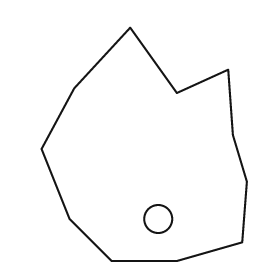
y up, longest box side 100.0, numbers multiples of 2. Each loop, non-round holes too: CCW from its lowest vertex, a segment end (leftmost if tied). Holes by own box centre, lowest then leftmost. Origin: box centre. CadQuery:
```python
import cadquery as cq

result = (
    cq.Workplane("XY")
    .moveTo(-14.0, -50.0)
    .lineTo(14.0, -50.0)
    .lineTo(42.0, -42.0)
    .lineTo(44.0, -16.0)
    .lineTo(38.0, 4.0)
    .lineTo(36.0, 32.0)
    .lineTo(14.0, 22.0)
    .lineTo(-6.0, 50.0)
    .lineTo(-30.0, 24.0)
    .lineTo(-44.0, -2.0)
    .lineTo(-32.0, -32.0)
    .close()
    .moveTo(6.0, -32.0)
    .circle(6.0)
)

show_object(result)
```